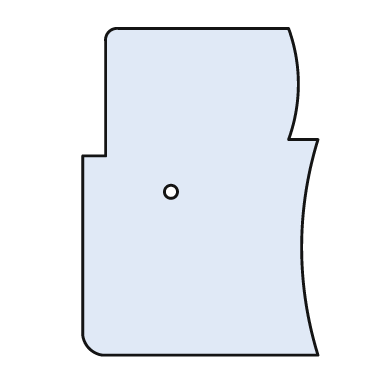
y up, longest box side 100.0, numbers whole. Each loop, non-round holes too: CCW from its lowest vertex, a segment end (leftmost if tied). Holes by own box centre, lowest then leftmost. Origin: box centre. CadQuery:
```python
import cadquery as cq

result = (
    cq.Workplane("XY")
    .moveTo(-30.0, -50.0)
    .lineTo(36.0, -50.0)
    .threePointArc((31.0, -17.0), (36.0, 16.0))
    .lineTo(27.0, 16.0)
    .threePointArc((30.0, 33.0), (27.0, 50.0))
    .lineTo(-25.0, 50.0)
    .threePointArc((-28.0, 49.0), (-29.0, 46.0))
    .lineTo(-29.0, 11.0)
    .lineTo(-36.0, 11.0)
    .lineTo(-36.0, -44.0)
    .threePointArc((-34.0, -48.0), (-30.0, -50.0))
    .close()
    .moveTo(-9.0, 0.0)
    .circle(2.0)
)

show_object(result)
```